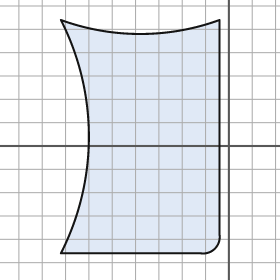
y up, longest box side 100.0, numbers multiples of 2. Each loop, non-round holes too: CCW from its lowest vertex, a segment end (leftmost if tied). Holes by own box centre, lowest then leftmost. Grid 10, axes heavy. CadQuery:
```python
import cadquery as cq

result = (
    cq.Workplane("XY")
    .moveTo(-72.0, -46.0)
    .lineTo(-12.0, -46.0)
    .threePointArc((-6.0, -44.0), (-4.0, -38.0))
    .lineTo(-4.0, 54.0)
    .threePointArc((-38.0, 48.0), (-72.0, 54.0))
    .threePointArc((-60.0, 4.0), (-72.0, -46.0))
    .close()
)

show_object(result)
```